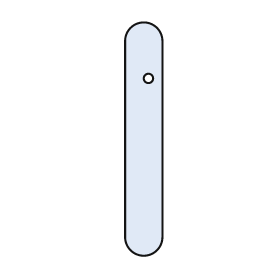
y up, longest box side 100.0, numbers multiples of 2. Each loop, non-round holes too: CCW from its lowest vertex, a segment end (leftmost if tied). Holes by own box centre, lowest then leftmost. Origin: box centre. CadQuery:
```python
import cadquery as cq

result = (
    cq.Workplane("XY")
    .moveTo(-8.0, -42.0)
    .threePointArc((0.0, -50.0), (8.0, -42.0))
    .lineTo(8.0, 42.0)
    .threePointArc((0.0, 50.0), (-8.0, 42.0))
    .close()
    .moveTo(2.0, 26.0)
    .circle(2.0)
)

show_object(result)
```